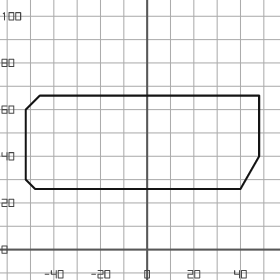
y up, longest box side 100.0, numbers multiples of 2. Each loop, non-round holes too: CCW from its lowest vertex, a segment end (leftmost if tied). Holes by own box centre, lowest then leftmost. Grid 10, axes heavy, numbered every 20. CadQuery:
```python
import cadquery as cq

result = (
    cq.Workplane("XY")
    .moveTo(-48.0, 26.0)
    .lineTo(40.0, 26.0)
    .lineTo(48.0, 40.0)
    .lineTo(48.0, 66.0)
    .lineTo(-46.0, 66.0)
    .lineTo(-52.0, 60.0)
    .lineTo(-52.0, 30.0)
    .close()
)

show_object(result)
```